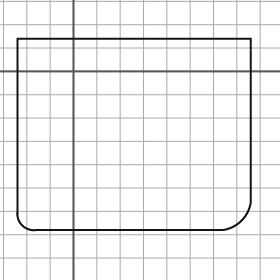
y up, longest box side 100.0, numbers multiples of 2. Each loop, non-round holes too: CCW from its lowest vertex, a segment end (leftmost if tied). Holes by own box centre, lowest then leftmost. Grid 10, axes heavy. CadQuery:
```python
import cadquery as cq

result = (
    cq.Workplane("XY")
    .moveTo(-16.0, -68.0)
    .lineTo(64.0, -68.0)
    .threePointArc((72.0, -64.0), (76.0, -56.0))
    .lineTo(76.0, 14.0)
    .lineTo(-24.0, 14.0)
    .lineTo(-24.0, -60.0)
    .threePointArc((-22.0, -66.0), (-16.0, -68.0))
    .close()
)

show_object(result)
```